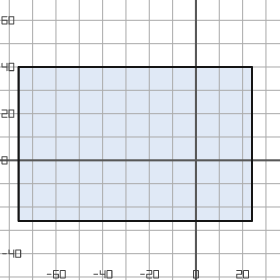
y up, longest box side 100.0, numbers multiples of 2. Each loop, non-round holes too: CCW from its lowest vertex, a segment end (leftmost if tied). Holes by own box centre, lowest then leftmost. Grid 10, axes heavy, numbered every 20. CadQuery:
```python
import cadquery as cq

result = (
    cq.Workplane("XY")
    .moveTo(-76.0, -26.0)
    .lineTo(24.0, -26.0)
    .lineTo(24.0, 40.0)
    .lineTo(-76.0, 40.0)
    .close()
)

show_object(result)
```